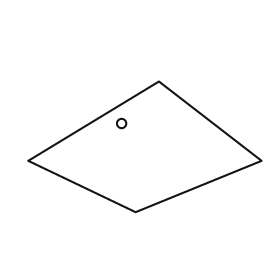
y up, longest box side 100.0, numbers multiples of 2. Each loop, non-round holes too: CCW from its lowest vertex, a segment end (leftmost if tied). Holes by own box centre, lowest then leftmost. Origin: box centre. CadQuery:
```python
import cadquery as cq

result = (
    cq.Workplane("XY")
    .moveTo(-4.0, -28.0)
    .lineTo(50.0, -6.0)
    .lineTo(6.0, 28.0)
    .lineTo(-50.0, -6.0)
    .close()
    .moveTo(-10.0, 10.0)
    .circle(2.0)
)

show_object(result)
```